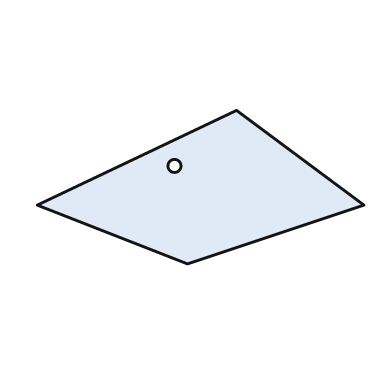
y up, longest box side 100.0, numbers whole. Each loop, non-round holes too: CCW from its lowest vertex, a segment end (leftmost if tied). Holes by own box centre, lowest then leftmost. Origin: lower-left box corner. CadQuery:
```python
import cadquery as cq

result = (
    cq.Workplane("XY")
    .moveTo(46.0, 0.0)
    .lineTo(100.0, 18.0)
    .lineTo(61.0, 47.0)
    .lineTo(0.0, 18.0)
    .close()
    .moveTo(42.0, 30.0)
    .circle(2.0)
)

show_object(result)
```